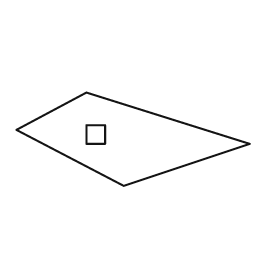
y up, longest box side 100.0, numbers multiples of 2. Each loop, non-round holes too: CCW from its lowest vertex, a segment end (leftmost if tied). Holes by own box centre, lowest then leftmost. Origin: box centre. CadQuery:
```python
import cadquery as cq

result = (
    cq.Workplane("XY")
    .moveTo(-4.0, -20.0)
    .lineTo(50.0, -2.0)
    .lineTo(-20.0, 20.0)
    .lineTo(-50.0, 4.0)
    .close()
    .moveTo(-20.0, -2.0)
    .lineTo(-12.0, -2.0)
    .lineTo(-12.0, 6.0)
    .lineTo(-20.0, 6.0)
    .close()
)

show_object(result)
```